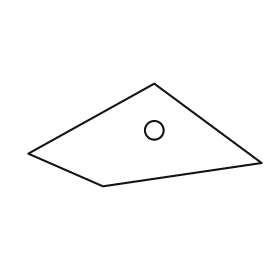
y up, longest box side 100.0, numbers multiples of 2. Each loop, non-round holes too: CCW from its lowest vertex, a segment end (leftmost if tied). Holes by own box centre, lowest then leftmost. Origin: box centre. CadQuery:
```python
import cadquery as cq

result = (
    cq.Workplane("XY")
    .moveTo(-18.0, -22.0)
    .lineTo(50.0, -12.0)
    .lineTo(4.0, 22.0)
    .lineTo(-50.0, -8.0)
    .close()
    .moveTo(4.0, 2.0)
    .circle(4.0)
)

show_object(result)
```